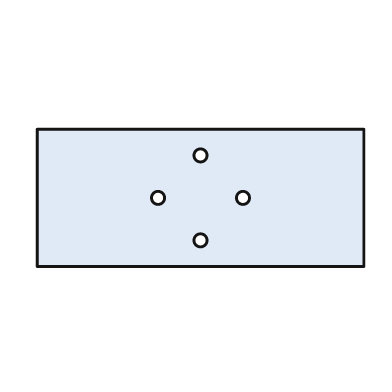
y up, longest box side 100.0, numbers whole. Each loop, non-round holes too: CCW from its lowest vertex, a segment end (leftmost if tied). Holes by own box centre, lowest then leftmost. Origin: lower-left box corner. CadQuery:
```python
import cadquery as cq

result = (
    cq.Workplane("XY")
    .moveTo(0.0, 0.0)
    .lineTo(100.0, 0.0)
    .lineTo(100.0, 42.0)
    .lineTo(0.0, 42.0)
    .close()
    .moveTo(50.0, 8.0)
    .circle(2.0)
    .moveTo(37.0, 21.0)
    .circle(2.0)
    .moveTo(63.0, 21.0)
    .circle(2.0)
    .moveTo(50.0, 34.0)
    .circle(2.0)
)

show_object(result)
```